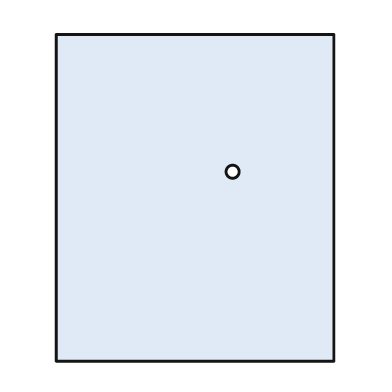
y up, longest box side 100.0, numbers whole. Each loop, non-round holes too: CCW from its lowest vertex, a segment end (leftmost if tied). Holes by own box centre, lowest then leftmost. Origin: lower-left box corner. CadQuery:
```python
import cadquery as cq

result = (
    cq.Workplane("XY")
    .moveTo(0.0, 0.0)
    .lineTo(85.0, 0.0)
    .lineTo(85.0, 100.0)
    .lineTo(0.0, 100.0)
    .close()
    .moveTo(54.0, 58.0)
    .circle(2.0)
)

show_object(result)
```